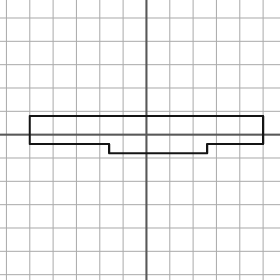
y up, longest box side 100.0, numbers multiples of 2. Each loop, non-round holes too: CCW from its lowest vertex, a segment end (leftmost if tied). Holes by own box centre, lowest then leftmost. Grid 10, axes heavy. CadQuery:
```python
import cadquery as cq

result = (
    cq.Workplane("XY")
    .moveTo(-16.0, -8.0)
    .lineTo(26.0, -8.0)
    .lineTo(26.0, -4.0)
    .lineTo(50.0, -4.0)
    .lineTo(50.0, 8.0)
    .lineTo(-50.0, 8.0)
    .lineTo(-50.0, -4.0)
    .lineTo(-16.0, -4.0)
    .close()
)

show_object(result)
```